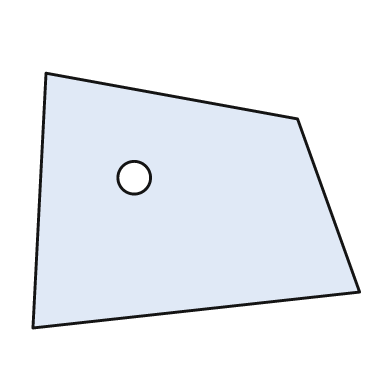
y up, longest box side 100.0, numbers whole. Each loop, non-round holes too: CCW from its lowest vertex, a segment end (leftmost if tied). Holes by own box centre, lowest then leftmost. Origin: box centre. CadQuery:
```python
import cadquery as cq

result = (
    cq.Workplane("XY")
    .moveTo(-50.0, -39.0)
    .lineTo(50.0, -28.0)
    .lineTo(31.0, 25.0)
    .lineTo(-46.0, 39.0)
    .close()
    .moveTo(-19.0, 7.0)
    .circle(5.0)
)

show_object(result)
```